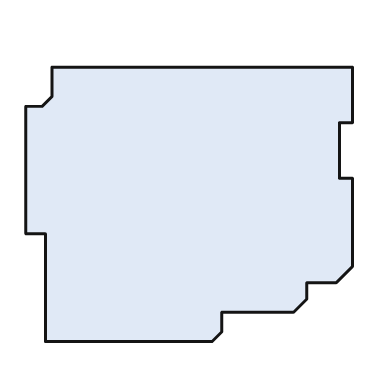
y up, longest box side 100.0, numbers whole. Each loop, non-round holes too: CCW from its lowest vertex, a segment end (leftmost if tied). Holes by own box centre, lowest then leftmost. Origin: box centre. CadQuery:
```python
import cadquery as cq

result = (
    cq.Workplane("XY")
    .moveTo(-44.0, -42.0)
    .lineTo(7.0, -42.0)
    .lineTo(10.0, -39.0)
    .lineTo(10.0, -33.0)
    .lineTo(32.0, -33.0)
    .lineTo(36.0, -29.0)
    .lineTo(36.0, -24.0)
    .lineTo(45.0, -24.0)
    .lineTo(50.0, -19.0)
    .lineTo(50.0, 8.0)
    .lineTo(46.0, 8.0)
    .lineTo(46.0, 25.0)
    .lineTo(50.0, 25.0)
    .lineTo(50.0, 42.0)
    .lineTo(-42.0, 42.0)
    .lineTo(-42.0, 33.0)
    .lineTo(-45.0, 30.0)
    .lineTo(-50.0, 30.0)
    .lineTo(-50.0, -9.0)
    .lineTo(-44.0, -9.0)
    .close()
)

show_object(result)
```